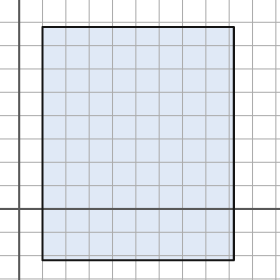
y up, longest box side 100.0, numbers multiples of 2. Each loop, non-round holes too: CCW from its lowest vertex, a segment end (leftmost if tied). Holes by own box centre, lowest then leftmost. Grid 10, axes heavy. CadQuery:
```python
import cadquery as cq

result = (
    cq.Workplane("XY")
    .moveTo(10.0, -22.0)
    .lineTo(92.0, -22.0)
    .lineTo(92.0, 78.0)
    .lineTo(10.0, 78.0)
    .close()
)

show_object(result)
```